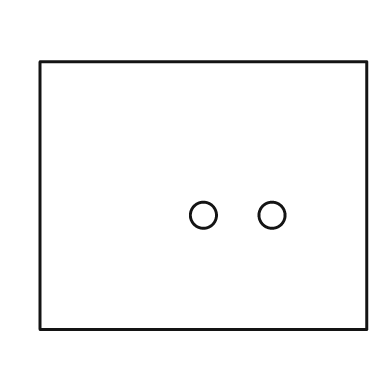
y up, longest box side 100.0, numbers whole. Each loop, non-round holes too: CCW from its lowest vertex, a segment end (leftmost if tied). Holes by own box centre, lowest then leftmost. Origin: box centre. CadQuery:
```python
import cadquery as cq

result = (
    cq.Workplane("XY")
    .moveTo(-50.0, -41.0)
    .lineTo(50.0, -41.0)
    .lineTo(50.0, 41.0)
    .lineTo(-50.0, 41.0)
    .close()
    .moveTo(0.0, -6.0)
    .circle(4.0)
    .moveTo(21.0, -6.0)
    .circle(4.0)
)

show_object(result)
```